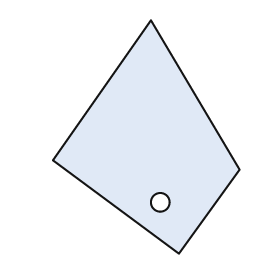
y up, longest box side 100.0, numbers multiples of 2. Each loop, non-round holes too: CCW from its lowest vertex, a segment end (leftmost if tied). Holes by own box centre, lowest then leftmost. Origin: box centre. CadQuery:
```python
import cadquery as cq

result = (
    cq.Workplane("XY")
    .moveTo(14.0, -50.0)
    .lineTo(40.0, -14.0)
    .lineTo(2.0, 50.0)
    .lineTo(-40.0, -10.0)
    .close()
    .moveTo(6.0, -28.0)
    .circle(4.0)
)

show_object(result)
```